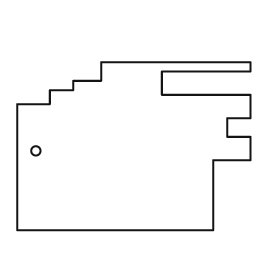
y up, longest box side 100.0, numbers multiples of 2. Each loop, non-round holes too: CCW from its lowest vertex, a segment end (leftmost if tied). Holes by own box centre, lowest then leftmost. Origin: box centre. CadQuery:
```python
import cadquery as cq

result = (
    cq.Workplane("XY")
    .moveTo(-50.0, -36.0)
    .lineTo(34.0, -36.0)
    .lineTo(34.0, -6.0)
    .lineTo(50.0, -6.0)
    .lineTo(50.0, 4.0)
    .lineTo(40.0, 4.0)
    .lineTo(40.0, 12.0)
    .lineTo(50.0, 12.0)
    .lineTo(50.0, 22.0)
    .lineTo(12.0, 22.0)
    .lineTo(12.0, 32.0)
    .lineTo(50.0, 32.0)
    .lineTo(50.0, 36.0)
    .lineTo(-14.0, 36.0)
    .lineTo(-14.0, 28.0)
    .lineTo(-26.0, 28.0)
    .lineTo(-26.0, 24.0)
    .lineTo(-36.0, 24.0)
    .lineTo(-36.0, 18.0)
    .lineTo(-50.0, 18.0)
    .close()
    .moveTo(-42.0, -2.0)
    .circle(2.0)
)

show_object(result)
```